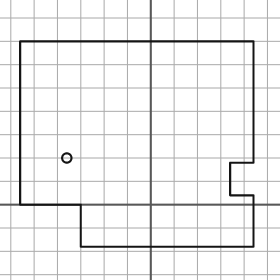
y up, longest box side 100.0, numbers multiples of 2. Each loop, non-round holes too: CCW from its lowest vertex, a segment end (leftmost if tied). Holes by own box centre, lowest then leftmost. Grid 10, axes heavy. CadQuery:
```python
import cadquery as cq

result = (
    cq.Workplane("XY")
    .moveTo(-30.0, -18.0)
    .lineTo(44.0, -18.0)
    .lineTo(44.0, 4.0)
    .lineTo(34.0, 4.0)
    .lineTo(34.0, 18.0)
    .lineTo(44.0, 18.0)
    .lineTo(44.0, 70.0)
    .lineTo(-56.0, 70.0)
    .lineTo(-56.0, 0.0)
    .lineTo(-30.0, 0.0)
    .close()
    .moveTo(-36.0, 20.0)
    .circle(2.0)
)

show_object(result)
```